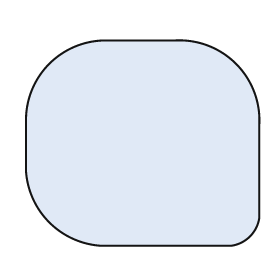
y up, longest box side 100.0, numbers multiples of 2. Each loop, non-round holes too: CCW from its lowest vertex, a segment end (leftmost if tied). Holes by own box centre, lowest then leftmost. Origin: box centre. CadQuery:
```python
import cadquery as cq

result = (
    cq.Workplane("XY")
    .moveTo(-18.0, -44.0)
    .lineTo(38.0, -44.0)
    .threePointArc((46.0, -40.0), (50.0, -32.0))
    .lineTo(50.0, 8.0)
    .threePointArc((40.0, 34.0), (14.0, 44.0))
    .lineTo(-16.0, 44.0)
    .threePointArc((-40.0, 34.0), (-50.0, 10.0))
    .lineTo(-50.0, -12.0)
    .threePointArc((-40.0, -34.0), (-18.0, -44.0))
    .close()
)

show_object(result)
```